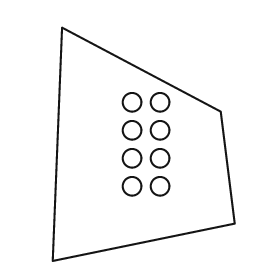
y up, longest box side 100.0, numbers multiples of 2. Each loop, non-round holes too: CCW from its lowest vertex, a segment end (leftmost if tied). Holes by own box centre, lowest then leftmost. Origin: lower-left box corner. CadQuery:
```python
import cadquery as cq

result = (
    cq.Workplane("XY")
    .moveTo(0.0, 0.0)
    .lineTo(78.0, 16.0)
    .lineTo(72.0, 64.0)
    .lineTo(4.0, 100.0)
    .close()
    .moveTo(34.0, 32.0)
    .circle(4.0)
    .moveTo(46.0, 32.0)
    .circle(4.0)
    .moveTo(34.0, 44.0)
    .circle(4.0)
    .moveTo(46.0, 44.0)
    .circle(4.0)
    .moveTo(34.0, 56.0)
    .circle(4.0)
    .moveTo(46.0, 56.0)
    .circle(4.0)
    .moveTo(34.0, 68.0)
    .circle(4.0)
    .moveTo(46.0, 68.0)
    .circle(4.0)
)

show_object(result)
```